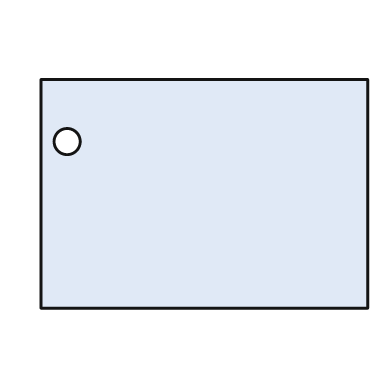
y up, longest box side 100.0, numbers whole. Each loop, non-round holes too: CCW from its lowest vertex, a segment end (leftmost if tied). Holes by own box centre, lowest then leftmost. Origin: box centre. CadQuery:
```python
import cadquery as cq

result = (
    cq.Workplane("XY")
    .moveTo(-50.0, -35.0)
    .lineTo(50.0, -35.0)
    .lineTo(50.0, 35.0)
    .lineTo(-50.0, 35.0)
    .close()
    .moveTo(-42.0, 16.0)
    .circle(4.0)
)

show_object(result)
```